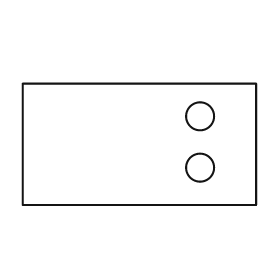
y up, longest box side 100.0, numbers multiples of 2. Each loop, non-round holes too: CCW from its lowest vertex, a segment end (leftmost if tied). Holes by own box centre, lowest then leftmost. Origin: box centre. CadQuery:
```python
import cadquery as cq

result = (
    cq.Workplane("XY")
    .moveTo(-50.0, -26.0)
    .lineTo(50.0, -26.0)
    .lineTo(50.0, 26.0)
    .lineTo(-50.0, 26.0)
    .close()
    .moveTo(26.0, -10.0)
    .circle(6.0)
    .moveTo(26.0, 12.0)
    .circle(6.0)
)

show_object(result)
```